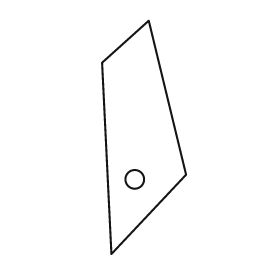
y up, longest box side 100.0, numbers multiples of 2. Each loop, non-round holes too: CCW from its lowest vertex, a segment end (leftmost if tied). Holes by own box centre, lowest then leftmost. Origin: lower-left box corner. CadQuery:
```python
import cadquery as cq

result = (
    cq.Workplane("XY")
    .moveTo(4.0, 0.0)
    .lineTo(36.0, 34.0)
    .lineTo(20.0, 100.0)
    .lineTo(0.0, 82.0)
    .close()
    .moveTo(14.0, 32.0)
    .circle(4.0)
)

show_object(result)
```